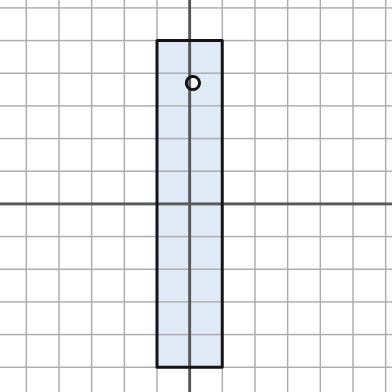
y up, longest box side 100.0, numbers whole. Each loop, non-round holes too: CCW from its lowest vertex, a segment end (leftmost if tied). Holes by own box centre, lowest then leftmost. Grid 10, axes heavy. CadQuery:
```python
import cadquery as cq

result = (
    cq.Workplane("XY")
    .moveTo(-10.0, -50.0)
    .lineTo(10.0, -50.0)
    .lineTo(10.0, 50.0)
    .lineTo(-10.0, 50.0)
    .close()
    .moveTo(1.0, 37.0)
    .circle(2.0)
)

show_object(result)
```